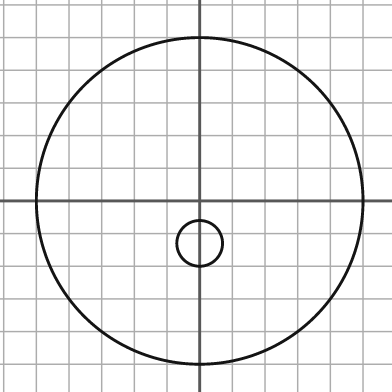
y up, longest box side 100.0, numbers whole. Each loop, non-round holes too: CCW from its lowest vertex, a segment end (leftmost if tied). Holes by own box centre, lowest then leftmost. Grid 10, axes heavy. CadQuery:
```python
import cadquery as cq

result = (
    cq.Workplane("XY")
    .moveTo(0.0, 0.0)
    .circle(50.0)
    .moveTo(0.0, -13.0)
    .circle(7.0)
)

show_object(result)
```